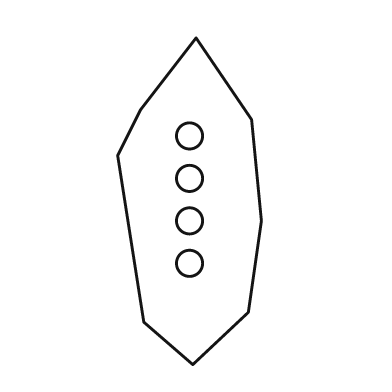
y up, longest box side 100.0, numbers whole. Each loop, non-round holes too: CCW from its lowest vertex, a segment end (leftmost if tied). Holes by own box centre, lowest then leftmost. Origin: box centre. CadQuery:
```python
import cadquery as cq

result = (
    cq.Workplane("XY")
    .moveTo(1.0, -50.0)
    .lineTo(18.0, -34.0)
    .lineTo(22.0, -6.0)
    .lineTo(19.0, 25.0)
    .lineTo(2.0, 50.0)
    .lineTo(-15.0, 28.0)
    .lineTo(-22.0, 14.0)
    .lineTo(-14.0, -37.0)
    .close()
    .moveTo(0.0, -19.0)
    .circle(4.0)
    .moveTo(0.0, -6.0)
    .circle(4.0)
    .moveTo(0.0, 7.0)
    .circle(4.0)
    .moveTo(0.0, 20.0)
    .circle(4.0)
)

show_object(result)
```